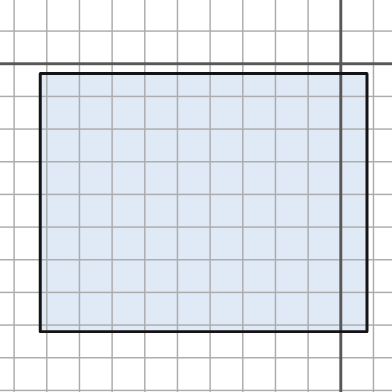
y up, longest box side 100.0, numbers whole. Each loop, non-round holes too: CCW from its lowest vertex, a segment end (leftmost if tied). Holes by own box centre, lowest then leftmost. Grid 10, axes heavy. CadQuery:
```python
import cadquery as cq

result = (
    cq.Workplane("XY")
    .moveTo(-92.0, -82.0)
    .lineTo(8.0, -82.0)
    .lineTo(8.0, -3.0)
    .lineTo(-92.0, -3.0)
    .close()
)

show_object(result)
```